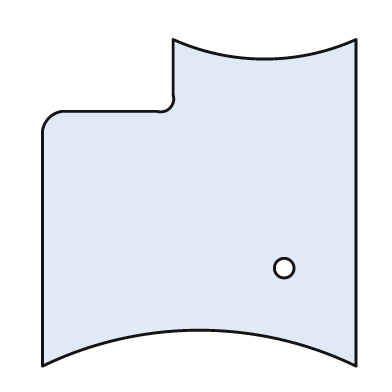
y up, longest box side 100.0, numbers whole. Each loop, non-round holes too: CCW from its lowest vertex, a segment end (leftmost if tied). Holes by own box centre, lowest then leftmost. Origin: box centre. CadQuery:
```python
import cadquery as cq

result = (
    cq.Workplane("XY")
    .moveTo(-48.0, -50.0)
    .threePointArc((0.0, -39.0), (48.0, -50.0))
    .lineTo(48.0, 50.0)
    .threePointArc((20.0, 44.0), (-8.0, 50.0))
    .lineTo(-8.0, 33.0)
    .threePointArc((-9.0, 29.0), (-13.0, 28.0))
    .lineTo(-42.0, 28.0)
    .threePointArc((-46.0, 26.0), (-48.0, 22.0))
    .close()
    .moveTo(26.0, -20.0)
    .circle(3.0)
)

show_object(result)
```